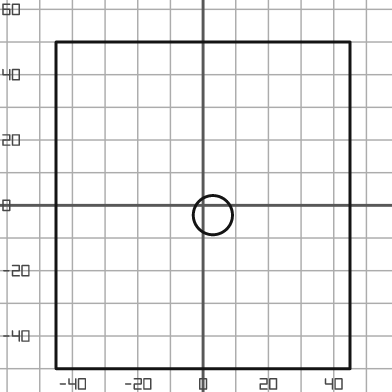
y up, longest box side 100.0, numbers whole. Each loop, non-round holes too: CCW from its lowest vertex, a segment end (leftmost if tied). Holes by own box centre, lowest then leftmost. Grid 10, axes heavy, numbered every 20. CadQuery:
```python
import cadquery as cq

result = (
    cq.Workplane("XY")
    .moveTo(-45.0, -50.0)
    .lineTo(45.0, -50.0)
    .lineTo(45.0, 50.0)
    .lineTo(-45.0, 50.0)
    .close()
    .moveTo(3.0, -3.0)
    .circle(6.0)
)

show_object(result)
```